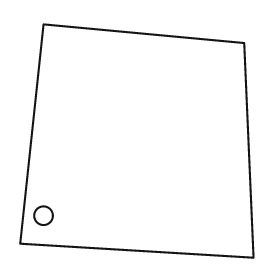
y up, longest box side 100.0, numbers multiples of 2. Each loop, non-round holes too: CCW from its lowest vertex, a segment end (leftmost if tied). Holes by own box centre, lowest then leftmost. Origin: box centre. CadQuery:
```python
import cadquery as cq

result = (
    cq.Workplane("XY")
    .moveTo(50.0, -50.0)
    .lineTo(46.0, 42.0)
    .lineTo(-40.0, 50.0)
    .lineTo(-50.0, -44.0)
    .close()
    .moveTo(-40.0, -32.0)
    .circle(4.0)
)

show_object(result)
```